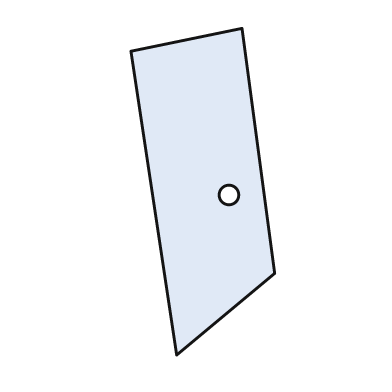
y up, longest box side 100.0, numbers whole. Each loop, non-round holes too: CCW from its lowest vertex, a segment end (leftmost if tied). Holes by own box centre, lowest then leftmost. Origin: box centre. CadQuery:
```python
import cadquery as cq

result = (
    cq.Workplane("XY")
    .moveTo(-8.0, -50.0)
    .lineTo(22.0, -25.0)
    .lineTo(12.0, 50.0)
    .lineTo(-22.0, 43.0)
    .close()
    .moveTo(8.0, -1.0)
    .circle(3.0)
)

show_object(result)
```